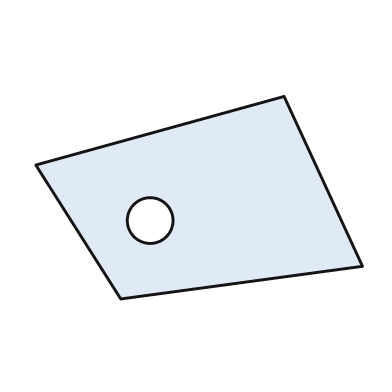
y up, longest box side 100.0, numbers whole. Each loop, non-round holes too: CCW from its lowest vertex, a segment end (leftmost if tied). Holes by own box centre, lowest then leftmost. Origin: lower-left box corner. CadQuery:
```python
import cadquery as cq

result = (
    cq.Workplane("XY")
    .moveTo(26.0, 0.0)
    .lineTo(100.0, 10.0)
    .lineTo(76.0, 62.0)
    .lineTo(0.0, 41.0)
    .close()
    .moveTo(35.0, 24.0)
    .circle(7.0)
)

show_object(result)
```